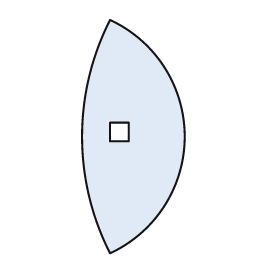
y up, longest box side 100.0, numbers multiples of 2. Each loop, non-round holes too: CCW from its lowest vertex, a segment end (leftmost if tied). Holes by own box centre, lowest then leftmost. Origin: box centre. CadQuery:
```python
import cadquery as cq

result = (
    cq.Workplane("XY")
    .moveTo(-10.0, -50.0)
    .threePointArc((22.0, 0.0), (-10.0, 50.0))
    .threePointArc((-22.0, 0.0), (-10.0, -50.0))
    .close()
    .moveTo(-10.0, -2.0)
    .lineTo(-2.0, -2.0)
    .lineTo(-2.0, 6.0)
    .lineTo(-10.0, 6.0)
    .close()
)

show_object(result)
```